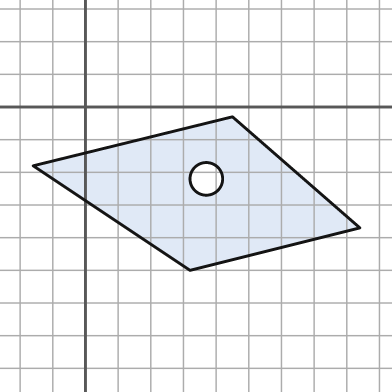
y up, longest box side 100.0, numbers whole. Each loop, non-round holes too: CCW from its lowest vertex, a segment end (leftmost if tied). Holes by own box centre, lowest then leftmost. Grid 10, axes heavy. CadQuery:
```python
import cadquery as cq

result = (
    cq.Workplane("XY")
    .moveTo(32.0, -50.0)
    .lineTo(84.0, -37.0)
    .lineTo(45.0, -3.0)
    .lineTo(-16.0, -18.0)
    .close()
    .moveTo(37.0, -22.0)
    .circle(5.0)
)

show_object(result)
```